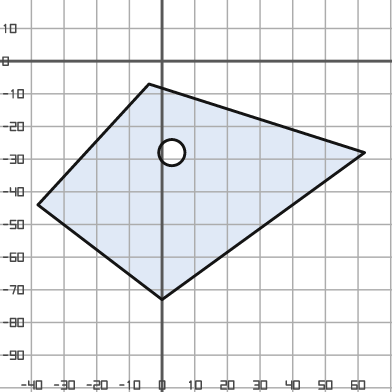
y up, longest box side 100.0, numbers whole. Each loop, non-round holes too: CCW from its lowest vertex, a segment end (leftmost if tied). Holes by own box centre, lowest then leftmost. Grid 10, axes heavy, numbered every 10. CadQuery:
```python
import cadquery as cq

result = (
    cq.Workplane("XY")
    .moveTo(0.0, -73.0)
    .lineTo(62.0, -28.0)
    .lineTo(-4.0, -7.0)
    .lineTo(-38.0, -44.0)
    .close()
    .moveTo(3.0, -28.0)
    .circle(4.0)
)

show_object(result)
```